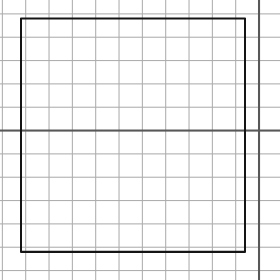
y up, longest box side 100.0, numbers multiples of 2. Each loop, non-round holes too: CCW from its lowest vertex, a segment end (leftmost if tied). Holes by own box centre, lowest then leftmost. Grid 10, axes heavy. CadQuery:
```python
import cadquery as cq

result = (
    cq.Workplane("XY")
    .moveTo(-102.0, -52.0)
    .lineTo(-6.0, -52.0)
    .lineTo(-6.0, 48.0)
    .lineTo(-102.0, 48.0)
    .close()
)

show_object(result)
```